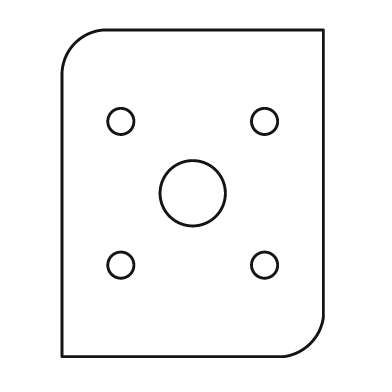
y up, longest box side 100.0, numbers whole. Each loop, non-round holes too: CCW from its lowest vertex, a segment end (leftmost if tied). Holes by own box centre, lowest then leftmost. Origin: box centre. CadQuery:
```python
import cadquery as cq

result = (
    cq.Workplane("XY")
    .moveTo(-40.0, -50.0)
    .lineTo(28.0, -50.0)
    .threePointArc((36.0, -46.0), (40.0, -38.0))
    .lineTo(40.0, 50.0)
    .lineTo(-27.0, 50.0)
    .threePointArc((-36.0, 46.0), (-40.0, 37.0))
    .close()
    .moveTo(-22.0, -22.0)
    .circle(4.0)
    .moveTo(22.0, -22.0)
    .circle(4.0)
    .moveTo(0.0, 0.0)
    .circle(10.0)
    .moveTo(-22.0, 22.0)
    .circle(4.0)
    .moveTo(22.0, 22.0)
    .circle(4.0)
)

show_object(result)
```